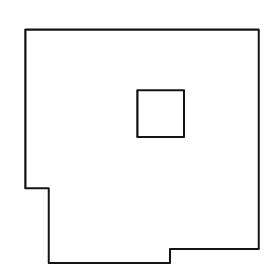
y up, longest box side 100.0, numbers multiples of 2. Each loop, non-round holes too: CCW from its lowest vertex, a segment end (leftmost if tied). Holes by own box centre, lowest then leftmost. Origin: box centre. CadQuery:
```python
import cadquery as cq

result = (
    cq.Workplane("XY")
    .moveTo(-40.0, -50.0)
    .lineTo(12.0, -50.0)
    .lineTo(12.0, -44.0)
    .lineTo(50.0, -44.0)
    .lineTo(50.0, 50.0)
    .lineTo(-50.0, 50.0)
    .lineTo(-50.0, -18.0)
    .lineTo(-40.0, -18.0)
    .close()
    .moveTo(-2.0, 4.0)
    .lineTo(18.0, 4.0)
    .lineTo(18.0, 24.0)
    .lineTo(-2.0, 24.0)
    .close()
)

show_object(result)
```